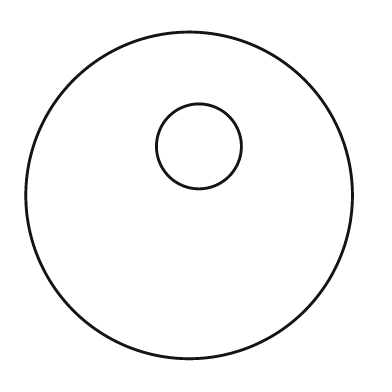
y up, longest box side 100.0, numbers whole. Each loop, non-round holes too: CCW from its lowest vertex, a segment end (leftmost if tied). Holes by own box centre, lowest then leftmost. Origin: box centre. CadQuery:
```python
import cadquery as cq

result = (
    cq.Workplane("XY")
    .moveTo(0.0, 0.0)
    .circle(50.0)
    .moveTo(3.0, 15.0)
    .circle(13.0)
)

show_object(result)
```